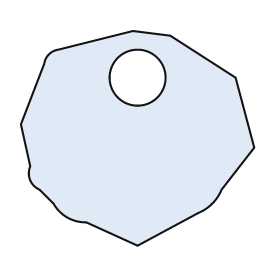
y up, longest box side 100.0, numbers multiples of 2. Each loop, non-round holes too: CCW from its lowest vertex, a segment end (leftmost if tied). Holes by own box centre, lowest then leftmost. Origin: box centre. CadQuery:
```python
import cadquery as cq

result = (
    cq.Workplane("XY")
    .moveTo(0.0, -46.0)
    .lineTo(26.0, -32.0)
    .threePointArc((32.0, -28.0), (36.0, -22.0))
    .lineTo(50.0, -4.0)
    .lineTo(42.0, 26.0)
    .lineTo(14.0, 44.0)
    .lineTo(-2.0, 46.0)
    .lineTo(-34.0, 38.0)
    .threePointArc((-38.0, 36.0), (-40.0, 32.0))
    .lineTo(-50.0, 6.0)
    .lineTo(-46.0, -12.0)
    .threePointArc((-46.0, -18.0), (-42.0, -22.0))
    .lineTo(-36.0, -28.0)
    .threePointArc((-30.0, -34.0), (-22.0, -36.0))
    .close()
    .moveTo(0.0, 26.0)
    .circle(12.0)
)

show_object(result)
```